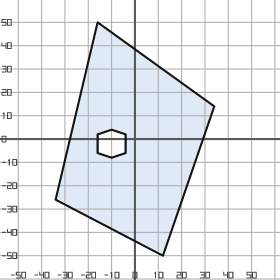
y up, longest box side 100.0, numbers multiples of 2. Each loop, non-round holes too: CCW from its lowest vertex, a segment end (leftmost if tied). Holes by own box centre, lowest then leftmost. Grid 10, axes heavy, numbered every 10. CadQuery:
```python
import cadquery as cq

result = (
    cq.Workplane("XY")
    .moveTo(12.0, -50.0)
    .lineTo(34.0, 14.0)
    .lineTo(-16.0, 50.0)
    .lineTo(-34.0, -26.0)
    .close()
    .moveTo(-10.0, -8.0)
    .lineTo(-4.0, -6.0)
    .lineTo(-4.0, 2.0)
    .lineTo(-10.0, 4.0)
    .lineTo(-16.0, 2.0)
    .lineTo(-16.0, -6.0)
    .close()
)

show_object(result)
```